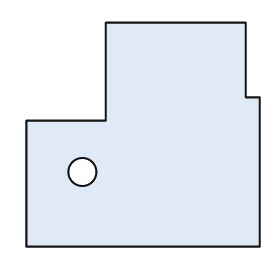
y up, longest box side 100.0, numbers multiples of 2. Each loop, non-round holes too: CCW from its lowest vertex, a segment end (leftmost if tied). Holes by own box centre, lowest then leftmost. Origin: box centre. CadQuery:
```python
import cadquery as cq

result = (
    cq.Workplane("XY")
    .moveTo(-50.0, -48.0)
    .lineTo(50.0, -48.0)
    .lineTo(50.0, 16.0)
    .lineTo(44.0, 16.0)
    .lineTo(44.0, 48.0)
    .lineTo(-16.0, 48.0)
    .lineTo(-16.0, 6.0)
    .lineTo(-50.0, 6.0)
    .close()
    .moveTo(-26.0, -16.0)
    .circle(6.0)
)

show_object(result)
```